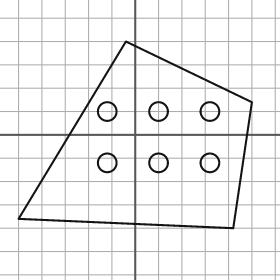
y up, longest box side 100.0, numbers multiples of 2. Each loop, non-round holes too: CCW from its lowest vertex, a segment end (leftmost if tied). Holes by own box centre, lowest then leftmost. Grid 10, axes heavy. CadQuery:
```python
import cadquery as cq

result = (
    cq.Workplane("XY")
    .moveTo(42.0, -40.0)
    .lineTo(50.0, 14.0)
    .lineTo(-4.0, 40.0)
    .lineTo(-50.0, -36.0)
    .close()
    .moveTo(-12.0, -12.0)
    .circle(4.0)
    .moveTo(10.0, -12.0)
    .circle(4.0)
    .moveTo(32.0, -12.0)
    .circle(4.0)
    .moveTo(-12.0, 10.0)
    .circle(4.0)
    .moveTo(10.0, 10.0)
    .circle(4.0)
    .moveTo(32.0, 10.0)
    .circle(4.0)
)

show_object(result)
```